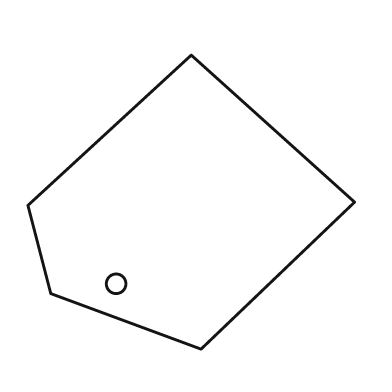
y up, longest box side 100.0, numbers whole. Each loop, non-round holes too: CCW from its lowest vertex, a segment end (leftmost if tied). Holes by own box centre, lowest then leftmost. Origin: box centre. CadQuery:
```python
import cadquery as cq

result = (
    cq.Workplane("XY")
    .moveTo(3.0, -45.0)
    .lineTo(50.0, 0.0)
    .lineTo(0.0, 45.0)
    .lineTo(-50.0, -1.0)
    .lineTo(-43.0, -28.0)
    .close()
    .moveTo(-23.0, -25.0)
    .circle(3.0)
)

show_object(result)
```